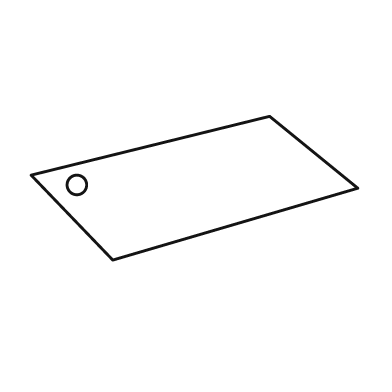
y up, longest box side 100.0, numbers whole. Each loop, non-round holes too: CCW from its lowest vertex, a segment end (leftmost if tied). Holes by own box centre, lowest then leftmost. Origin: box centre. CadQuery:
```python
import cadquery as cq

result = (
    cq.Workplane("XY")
    .moveTo(-25.0, -22.0)
    .lineTo(50.0, 0.0)
    .lineTo(23.0, 22.0)
    .lineTo(-50.0, 4.0)
    .close()
    .moveTo(-36.0, 1.0)
    .circle(3.0)
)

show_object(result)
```